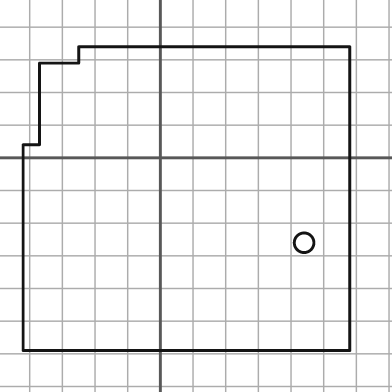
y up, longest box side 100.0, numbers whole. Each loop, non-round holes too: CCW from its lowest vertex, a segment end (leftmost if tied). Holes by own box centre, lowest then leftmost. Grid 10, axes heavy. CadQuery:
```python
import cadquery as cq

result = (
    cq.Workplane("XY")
    .moveTo(-42.0, -59.0)
    .lineTo(58.0, -59.0)
    .lineTo(58.0, 34.0)
    .lineTo(-25.0, 34.0)
    .lineTo(-25.0, 29.0)
    .lineTo(-37.0, 29.0)
    .lineTo(-37.0, 4.0)
    .lineTo(-42.0, 4.0)
    .close()
    .moveTo(44.0, -26.0)
    .circle(3.0)
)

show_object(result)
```